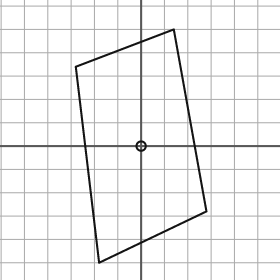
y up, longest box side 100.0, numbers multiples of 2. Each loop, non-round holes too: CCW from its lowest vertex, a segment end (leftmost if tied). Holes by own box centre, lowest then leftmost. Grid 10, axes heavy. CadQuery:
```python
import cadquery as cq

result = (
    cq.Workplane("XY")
    .moveTo(-18.0, -50.0)
    .lineTo(28.0, -28.0)
    .lineTo(14.0, 50.0)
    .lineTo(-28.0, 34.0)
    .close()
    .moveTo(0.0, 0.0)
    .circle(2.0)
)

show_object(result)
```